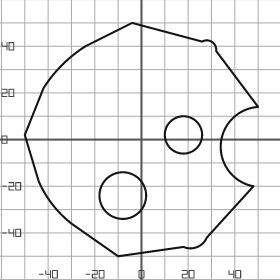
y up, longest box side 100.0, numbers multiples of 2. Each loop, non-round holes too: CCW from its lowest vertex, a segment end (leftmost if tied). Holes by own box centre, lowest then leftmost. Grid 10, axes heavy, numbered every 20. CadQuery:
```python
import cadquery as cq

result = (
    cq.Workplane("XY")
    .moveTo(-10.0, -50.0)
    .lineTo(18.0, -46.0)
    .threePointArc((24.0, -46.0), (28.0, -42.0))
    .lineTo(48.0, -20.0)
    .threePointArc((34.0, -2.0), (50.0, 14.0))
    .lineTo(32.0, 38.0)
    .threePointArc((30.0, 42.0), (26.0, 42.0))
    .lineTo(-4.0, 50.0)
    .lineTo(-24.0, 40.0)
    .threePointArc((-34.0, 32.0), (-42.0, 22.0))
    .lineTo(-50.0, 2.0)
    .lineTo(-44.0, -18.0)
    .threePointArc((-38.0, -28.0), (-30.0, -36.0))
    .close()
    .moveTo(-8.0, -24.0)
    .circle(10.0)
    .moveTo(18.0, 2.0)
    .circle(8.0)
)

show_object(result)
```